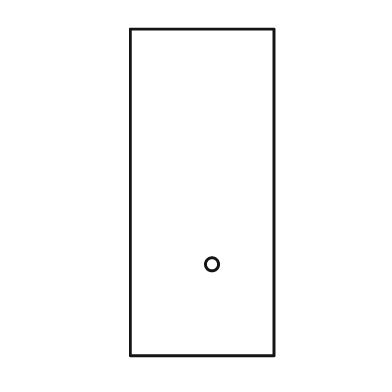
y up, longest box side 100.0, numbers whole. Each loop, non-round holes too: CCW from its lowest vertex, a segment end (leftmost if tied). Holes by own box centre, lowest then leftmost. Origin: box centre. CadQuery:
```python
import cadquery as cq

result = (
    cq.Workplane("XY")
    .moveTo(-22.0, -50.0)
    .lineTo(22.0, -50.0)
    .lineTo(22.0, 50.0)
    .lineTo(-22.0, 50.0)
    .close()
    .moveTo(3.0, -22.0)
    .circle(2.0)
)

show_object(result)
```